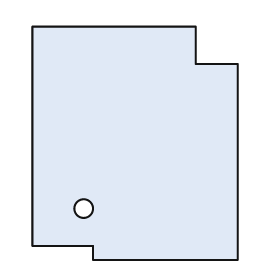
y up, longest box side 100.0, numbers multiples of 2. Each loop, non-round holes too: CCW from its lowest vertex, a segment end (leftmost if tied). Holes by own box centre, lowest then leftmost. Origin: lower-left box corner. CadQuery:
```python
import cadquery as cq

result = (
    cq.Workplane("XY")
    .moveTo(26.0, 0.0)
    .lineTo(88.0, 0.0)
    .lineTo(88.0, 84.0)
    .lineTo(70.0, 84.0)
    .lineTo(70.0, 100.0)
    .lineTo(0.0, 100.0)
    .lineTo(0.0, 6.0)
    .lineTo(26.0, 6.0)
    .close()
    .moveTo(22.0, 22.0)
    .circle(4.0)
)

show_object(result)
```